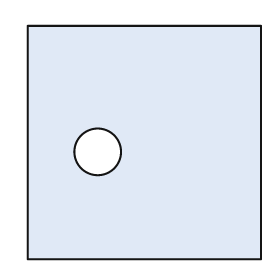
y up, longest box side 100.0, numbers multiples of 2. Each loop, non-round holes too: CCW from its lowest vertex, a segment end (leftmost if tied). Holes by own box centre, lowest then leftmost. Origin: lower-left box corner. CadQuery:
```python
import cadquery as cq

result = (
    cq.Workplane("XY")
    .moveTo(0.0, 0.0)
    .lineTo(100.0, 0.0)
    .lineTo(100.0, 100.0)
    .lineTo(0.0, 100.0)
    .close()
    .moveTo(30.0, 46.0)
    .circle(10.0)
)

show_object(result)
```